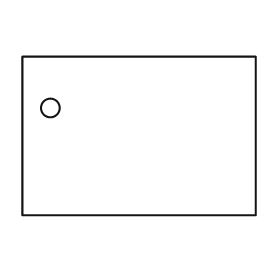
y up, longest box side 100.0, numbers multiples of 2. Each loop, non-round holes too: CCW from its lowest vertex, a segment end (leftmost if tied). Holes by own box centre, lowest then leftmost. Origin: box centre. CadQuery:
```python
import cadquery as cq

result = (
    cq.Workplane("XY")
    .moveTo(-50.0, -34.0)
    .lineTo(50.0, -34.0)
    .lineTo(50.0, 34.0)
    .lineTo(-50.0, 34.0)
    .close()
    .moveTo(-38.0, 12.0)
    .circle(4.0)
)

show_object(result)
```